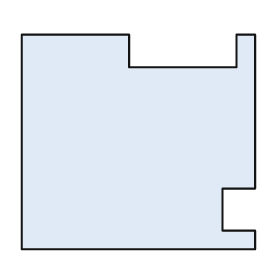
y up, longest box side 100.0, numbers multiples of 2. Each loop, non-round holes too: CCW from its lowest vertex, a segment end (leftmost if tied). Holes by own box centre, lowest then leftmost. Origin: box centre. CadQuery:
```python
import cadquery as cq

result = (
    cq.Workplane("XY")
    .moveTo(-50.0, -46.0)
    .lineTo(50.0, -46.0)
    .lineTo(50.0, -38.0)
    .lineTo(36.0, -38.0)
    .lineTo(36.0, -20.0)
    .lineTo(50.0, -20.0)
    .lineTo(50.0, 46.0)
    .lineTo(42.0, 46.0)
    .lineTo(42.0, 32.0)
    .lineTo(-4.0, 32.0)
    .lineTo(-4.0, 46.0)
    .lineTo(-50.0, 46.0)
    .close()
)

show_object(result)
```